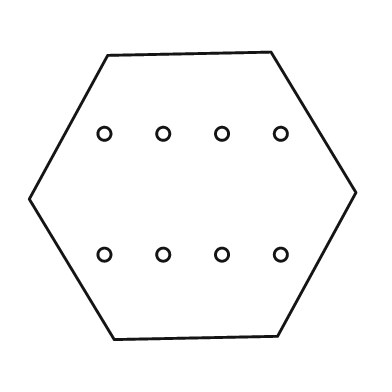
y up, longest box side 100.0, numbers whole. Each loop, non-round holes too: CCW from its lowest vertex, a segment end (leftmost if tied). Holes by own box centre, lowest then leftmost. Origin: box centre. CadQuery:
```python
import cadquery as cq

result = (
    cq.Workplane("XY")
    .moveTo(-24.0, -44.0)
    .lineTo(26.0, -43.0)
    .lineTo(50.0, 1.0)
    .lineTo(24.0, 44.0)
    .lineTo(-26.0, 43.0)
    .lineTo(-50.0, -1.0)
    .close()
    .moveTo(-27.0, -18.0)
    .circle(2.0)
    .moveTo(-9.0, -18.0)
    .circle(2.0)
    .moveTo(9.0, -18.0)
    .circle(2.0)
    .moveTo(27.0, -18.0)
    .circle(2.0)
    .moveTo(-27.0, 19.0)
    .circle(2.0)
    .moveTo(-9.0, 19.0)
    .circle(2.0)
    .moveTo(9.0, 19.0)
    .circle(2.0)
    .moveTo(27.0, 19.0)
    .circle(2.0)
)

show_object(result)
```